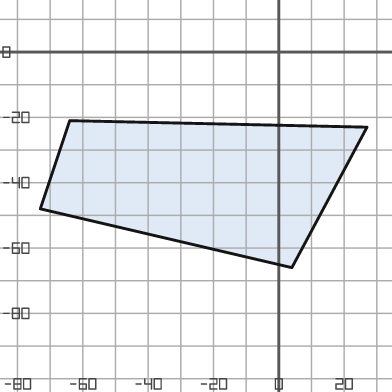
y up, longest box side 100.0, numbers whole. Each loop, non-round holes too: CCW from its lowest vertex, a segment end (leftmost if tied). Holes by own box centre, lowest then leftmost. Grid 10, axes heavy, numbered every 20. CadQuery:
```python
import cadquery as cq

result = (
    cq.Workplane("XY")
    .moveTo(4.0, -66.0)
    .lineTo(27.0, -23.0)
    .lineTo(-64.0, -21.0)
    .lineTo(-73.0, -48.0)
    .close()
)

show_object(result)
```